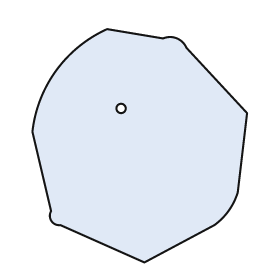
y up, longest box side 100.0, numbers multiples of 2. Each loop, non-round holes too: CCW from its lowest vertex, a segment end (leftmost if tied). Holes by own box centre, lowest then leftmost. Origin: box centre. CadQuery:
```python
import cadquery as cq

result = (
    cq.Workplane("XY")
    .moveTo(2.0, -50.0)
    .lineTo(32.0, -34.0)
    .threePointArc((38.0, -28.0), (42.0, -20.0))
    .lineTo(46.0, 14.0)
    .lineTo(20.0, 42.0)
    .threePointArc((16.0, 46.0), (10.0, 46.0))
    .lineTo(-14.0, 50.0)
    .threePointArc((-36.0, 32.0), (-46.0, 6.0))
    .lineTo(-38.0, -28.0)
    .threePointArc((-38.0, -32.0), (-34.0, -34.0))
    .close()
    .moveTo(-8.0, 16.0)
    .circle(2.0)
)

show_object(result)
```